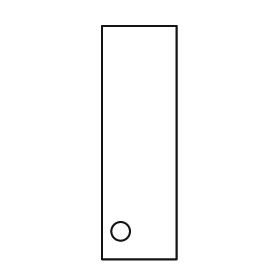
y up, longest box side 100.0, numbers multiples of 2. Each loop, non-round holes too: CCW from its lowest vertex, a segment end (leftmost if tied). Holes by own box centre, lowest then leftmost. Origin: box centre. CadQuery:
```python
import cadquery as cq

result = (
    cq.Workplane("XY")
    .moveTo(-16.0, -50.0)
    .lineTo(16.0, -50.0)
    .lineTo(16.0, 50.0)
    .lineTo(-16.0, 50.0)
    .close()
    .moveTo(-8.0, -38.0)
    .circle(4.0)
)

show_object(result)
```